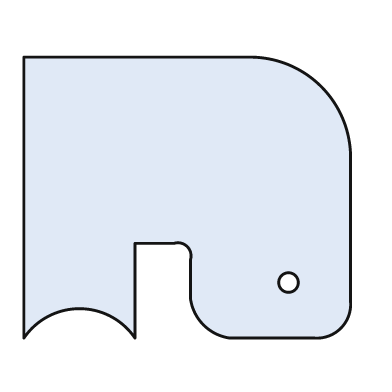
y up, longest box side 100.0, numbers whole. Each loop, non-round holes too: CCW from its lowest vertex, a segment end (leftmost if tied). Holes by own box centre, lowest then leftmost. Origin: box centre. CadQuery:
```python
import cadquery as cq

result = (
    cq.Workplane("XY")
    .moveTo(-50.0, -43.0)
    .threePointArc((-33.0, -34.0), (-16.0, -43.0))
    .lineTo(-16.0, -14.0)
    .lineTo(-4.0, -14.0)
    .threePointArc((0.0, -15.0), (1.0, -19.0))
    .lineTo(1.0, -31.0)
    .threePointArc((5.0, -39.0), (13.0, -43.0))
    .lineTo(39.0, -43.0)
    .threePointArc((47.0, -40.0), (50.0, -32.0))
    .lineTo(50.0, 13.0)
    .threePointArc((41.0, 34.0), (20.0, 43.0))
    .lineTo(-50.0, 43.0)
    .close()
    .moveTo(31.0, -26.0)
    .circle(3.0)
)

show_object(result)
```